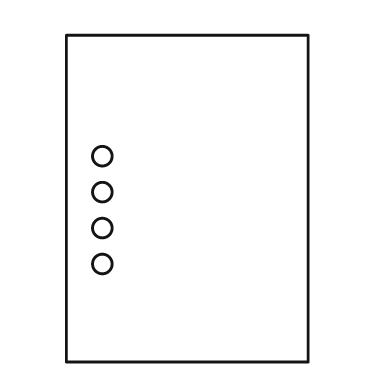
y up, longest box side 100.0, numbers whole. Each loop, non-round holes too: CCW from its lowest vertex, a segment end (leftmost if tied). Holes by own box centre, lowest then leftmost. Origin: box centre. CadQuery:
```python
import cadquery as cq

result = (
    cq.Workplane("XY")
    .moveTo(-37.0, -50.0)
    .lineTo(37.0, -50.0)
    .lineTo(37.0, 50.0)
    .lineTo(-37.0, 50.0)
    .close()
    .moveTo(-26.0, -20.0)
    .circle(3.0)
    .moveTo(-26.0, -9.0)
    .circle(3.0)
    .moveTo(-26.0, 2.0)
    .circle(3.0)
    .moveTo(-26.0, 13.0)
    .circle(3.0)
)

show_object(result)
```